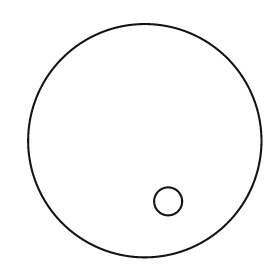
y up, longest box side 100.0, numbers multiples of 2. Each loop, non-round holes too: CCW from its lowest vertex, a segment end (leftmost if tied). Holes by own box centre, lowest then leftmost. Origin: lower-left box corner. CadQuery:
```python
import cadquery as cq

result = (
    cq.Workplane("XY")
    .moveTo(50.0, 50.0)
    .circle(50.0)
    .moveTo(60.0, 24.0)
    .circle(6.0)
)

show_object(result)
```